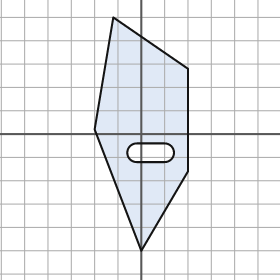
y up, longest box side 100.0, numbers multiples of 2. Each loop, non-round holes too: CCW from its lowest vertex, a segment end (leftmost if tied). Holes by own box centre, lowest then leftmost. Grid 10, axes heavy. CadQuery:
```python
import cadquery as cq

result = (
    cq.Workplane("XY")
    .moveTo(0.0, -50.0)
    .lineTo(20.0, -16.0)
    .lineTo(20.0, 28.0)
    .lineTo(-12.0, 50.0)
    .lineTo(-20.0, 2.0)
    .close()
    .moveTo(-2.0, -12.0)
    .lineTo(10.0, -12.0)
    .threePointArc((14.0, -8.0), (10.0, -4.0))
    .lineTo(-2.0, -4.0)
    .threePointArc((-6.0, -8.0), (-2.0, -12.0))
    .close()
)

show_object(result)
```